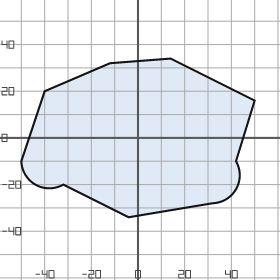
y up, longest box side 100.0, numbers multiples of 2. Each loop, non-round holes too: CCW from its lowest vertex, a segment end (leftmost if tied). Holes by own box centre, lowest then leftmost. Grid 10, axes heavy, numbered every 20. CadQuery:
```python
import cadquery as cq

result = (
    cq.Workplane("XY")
    .moveTo(-4.0, -34.0)
    .lineTo(32.0, -28.0)
    .threePointArc((42.0, -22.0), (42.0, -10.0))
    .lineTo(50.0, 16.0)
    .lineTo(14.0, 34.0)
    .lineTo(-12.0, 32.0)
    .lineTo(-40.0, 20.0)
    .lineTo(-50.0, -10.0)
    .threePointArc((-44.0, -20.0), (-32.0, -20.0))
    .close()
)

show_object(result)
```